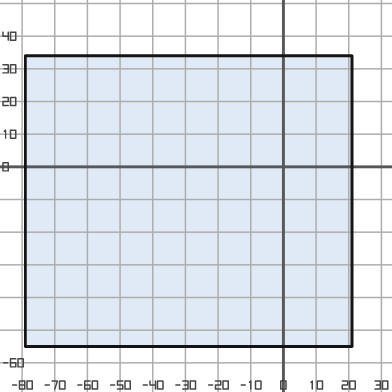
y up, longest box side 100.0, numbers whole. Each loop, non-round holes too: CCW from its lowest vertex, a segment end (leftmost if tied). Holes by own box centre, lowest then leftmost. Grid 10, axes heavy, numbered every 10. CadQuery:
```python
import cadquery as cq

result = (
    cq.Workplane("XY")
    .moveTo(-79.0, -55.0)
    .lineTo(21.0, -55.0)
    .lineTo(21.0, 34.0)
    .lineTo(-79.0, 34.0)
    .close()
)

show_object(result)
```